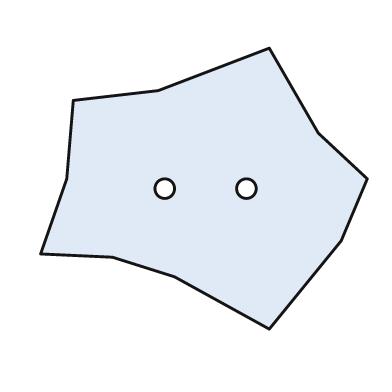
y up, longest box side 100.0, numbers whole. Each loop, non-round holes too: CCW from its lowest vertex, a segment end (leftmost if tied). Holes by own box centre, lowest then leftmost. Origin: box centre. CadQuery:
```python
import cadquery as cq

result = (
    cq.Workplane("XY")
    .moveTo(20.0, -43.0)
    .lineTo(42.0, -16.0)
    .lineTo(50.0, 3.0)
    .lineTo(35.0, 17.0)
    .lineTo(20.0, 43.0)
    .lineTo(-14.0, 30.0)
    .lineTo(-40.0, 27.0)
    .lineTo(-42.0, 3.0)
    .lineTo(-50.0, -20.0)
    .lineTo(-28.0, -21.0)
    .lineTo(-9.0, -27.0)
    .close()
    .moveTo(-12.0, 0.0)
    .circle(3.0)
    .moveTo(13.0, 0.0)
    .circle(3.0)
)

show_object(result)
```